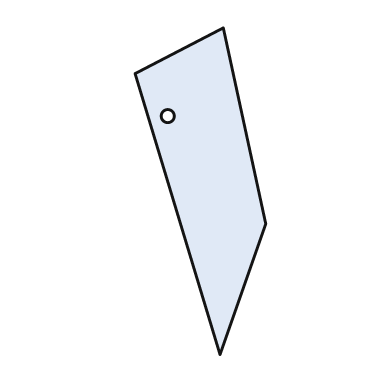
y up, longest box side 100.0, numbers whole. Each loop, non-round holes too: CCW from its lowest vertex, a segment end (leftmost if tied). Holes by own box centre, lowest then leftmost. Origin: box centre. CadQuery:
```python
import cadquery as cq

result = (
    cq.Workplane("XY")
    .moveTo(6.0, -50.0)
    .lineTo(20.0, -10.0)
    .lineTo(7.0, 50.0)
    .lineTo(-20.0, 36.0)
    .close()
    .moveTo(-10.0, 23.0)
    .circle(2.0)
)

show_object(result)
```